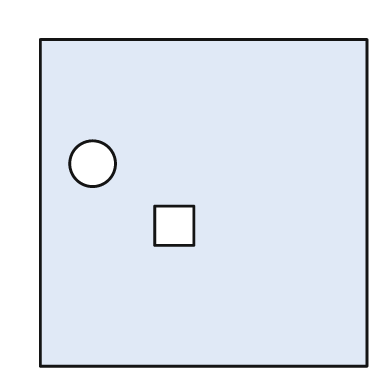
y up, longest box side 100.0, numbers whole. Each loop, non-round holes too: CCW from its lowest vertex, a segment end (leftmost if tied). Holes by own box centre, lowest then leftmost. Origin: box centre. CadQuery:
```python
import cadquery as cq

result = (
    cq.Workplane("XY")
    .moveTo(-50.0, -50.0)
    .lineTo(50.0, -50.0)
    .lineTo(50.0, 50.0)
    .lineTo(-50.0, 50.0)
    .close()
    .moveTo(-15.0, -13.0)
    .lineTo(-3.0, -13.0)
    .lineTo(-3.0, -1.0)
    .lineTo(-15.0, -1.0)
    .close()
    .moveTo(-34.0, 12.0)
    .circle(7.0)
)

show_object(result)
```